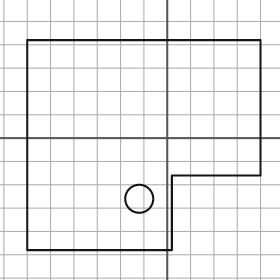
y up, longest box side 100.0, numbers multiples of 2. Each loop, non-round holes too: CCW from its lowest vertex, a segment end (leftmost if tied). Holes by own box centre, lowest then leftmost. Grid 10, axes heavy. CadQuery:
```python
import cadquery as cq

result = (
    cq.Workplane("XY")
    .moveTo(-60.0, -48.0)
    .lineTo(2.0, -48.0)
    .lineTo(2.0, -16.0)
    .lineTo(40.0, -16.0)
    .lineTo(40.0, 42.0)
    .lineTo(-60.0, 42.0)
    .close()
    .moveTo(-12.0, -26.0)
    .circle(6.0)
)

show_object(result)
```